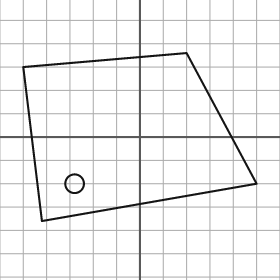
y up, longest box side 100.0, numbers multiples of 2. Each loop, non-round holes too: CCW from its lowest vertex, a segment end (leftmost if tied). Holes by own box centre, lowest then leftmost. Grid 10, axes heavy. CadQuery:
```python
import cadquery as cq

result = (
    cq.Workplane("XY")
    .moveTo(-42.0, -36.0)
    .lineTo(50.0, -20.0)
    .lineTo(20.0, 36.0)
    .lineTo(-50.0, 30.0)
    .close()
    .moveTo(-28.0, -20.0)
    .circle(4.0)
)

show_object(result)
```